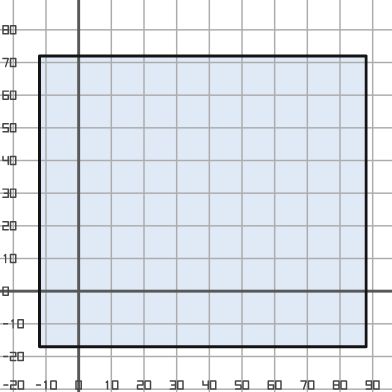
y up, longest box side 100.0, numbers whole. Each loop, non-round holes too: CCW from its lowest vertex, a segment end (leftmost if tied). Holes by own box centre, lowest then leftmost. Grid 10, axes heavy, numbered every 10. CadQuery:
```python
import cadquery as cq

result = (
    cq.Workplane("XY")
    .moveTo(-12.0, -17.0)
    .lineTo(88.0, -17.0)
    .lineTo(88.0, 72.0)
    .lineTo(-12.0, 72.0)
    .close()
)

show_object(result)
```